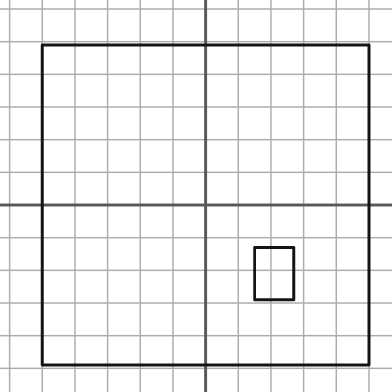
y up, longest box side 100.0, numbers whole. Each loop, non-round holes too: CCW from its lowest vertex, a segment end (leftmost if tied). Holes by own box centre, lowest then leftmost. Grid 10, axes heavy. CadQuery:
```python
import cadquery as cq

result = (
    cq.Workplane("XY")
    .moveTo(-50.0, -49.0)
    .lineTo(50.0, -49.0)
    .lineTo(50.0, 49.0)
    .lineTo(-50.0, 49.0)
    .close()
    .moveTo(15.0, -29.0)
    .lineTo(27.0, -29.0)
    .lineTo(27.0, -13.0)
    .lineTo(15.0, -13.0)
    .close()
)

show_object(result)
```